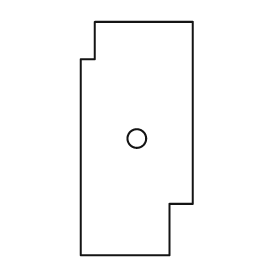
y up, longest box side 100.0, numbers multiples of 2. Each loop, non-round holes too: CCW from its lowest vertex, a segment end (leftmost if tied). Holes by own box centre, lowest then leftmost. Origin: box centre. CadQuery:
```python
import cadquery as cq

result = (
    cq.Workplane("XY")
    .moveTo(-24.0, -50.0)
    .lineTo(14.0, -50.0)
    .lineTo(14.0, -28.0)
    .lineTo(24.0, -28.0)
    .lineTo(24.0, 50.0)
    .lineTo(-18.0, 50.0)
    .lineTo(-18.0, 34.0)
    .lineTo(-24.0, 34.0)
    .close()
    .moveTo(0.0, 0.0)
    .circle(4.0)
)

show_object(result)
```